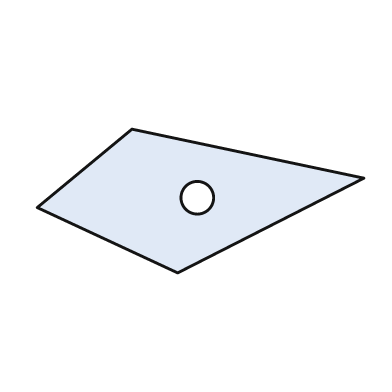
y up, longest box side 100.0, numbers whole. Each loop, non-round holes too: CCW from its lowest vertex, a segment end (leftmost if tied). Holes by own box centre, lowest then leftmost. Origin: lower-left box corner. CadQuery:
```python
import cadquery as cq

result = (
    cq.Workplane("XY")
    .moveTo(43.0, 0.0)
    .lineTo(100.0, 29.0)
    .lineTo(29.0, 44.0)
    .lineTo(0.0, 20.0)
    .close()
    .moveTo(49.0, 23.0)
    .circle(5.0)
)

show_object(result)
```